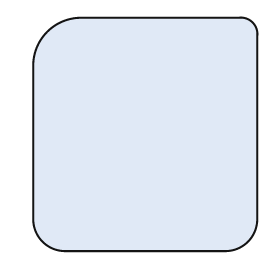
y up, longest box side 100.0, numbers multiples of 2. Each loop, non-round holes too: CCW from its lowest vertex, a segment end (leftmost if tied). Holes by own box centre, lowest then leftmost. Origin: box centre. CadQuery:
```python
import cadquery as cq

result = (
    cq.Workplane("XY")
    .moveTo(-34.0, -50.0)
    .lineTo(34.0, -50.0)
    .threePointArc((44.0, -46.0), (48.0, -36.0))
    .lineTo(48.0, 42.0)
    .threePointArc((46.0, 48.0), (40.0, 50.0))
    .lineTo(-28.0, 50.0)
    .threePointArc((-42.0, 44.0), (-48.0, 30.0))
    .lineTo(-48.0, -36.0)
    .threePointArc((-44.0, -46.0), (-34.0, -50.0))
    .close()
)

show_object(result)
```